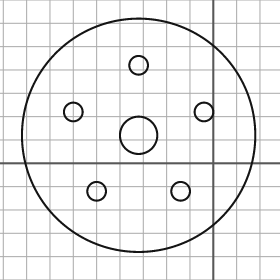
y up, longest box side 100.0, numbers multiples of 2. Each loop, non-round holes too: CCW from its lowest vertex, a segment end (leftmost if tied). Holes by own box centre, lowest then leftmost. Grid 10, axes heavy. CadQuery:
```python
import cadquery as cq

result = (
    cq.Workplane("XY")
    .moveTo(-32.0, 12.0)
    .circle(50.0)
    .moveTo(-50.0, -12.0)
    .circle(4.0)
    .moveTo(-14.0, -12.0)
    .circle(4.0)
    .moveTo(-32.0, 12.0)
    .circle(8.0)
    .moveTo(-60.0, 22.0)
    .circle(4.0)
    .moveTo(-4.0, 22.0)
    .circle(4.0)
    .moveTo(-32.0, 42.0)
    .circle(4.0)
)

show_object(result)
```